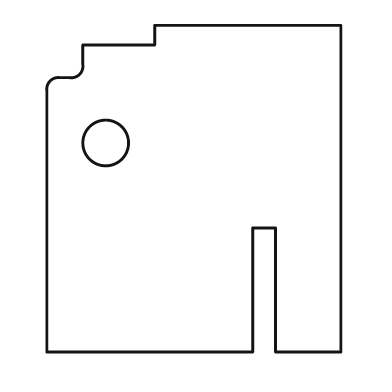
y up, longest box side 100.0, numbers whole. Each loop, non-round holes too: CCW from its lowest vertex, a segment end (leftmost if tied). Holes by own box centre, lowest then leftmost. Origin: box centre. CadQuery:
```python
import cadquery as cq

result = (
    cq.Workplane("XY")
    .moveTo(-45.0, -50.0)
    .lineTo(18.0, -50.0)
    .lineTo(18.0, -12.0)
    .lineTo(25.0, -12.0)
    .lineTo(25.0, -50.0)
    .lineTo(45.0, -50.0)
    .lineTo(45.0, 50.0)
    .lineTo(-12.0, 50.0)
    .lineTo(-12.0, 44.0)
    .lineTo(-34.0, 44.0)
    .lineTo(-34.0, 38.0)
    .threePointArc((-35.0, 35.0), (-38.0, 34.0))
    .lineTo(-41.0, 34.0)
    .threePointArc((-44.0, 33.0), (-45.0, 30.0))
    .close()
    .moveTo(-27.0, 14.0)
    .circle(7.0)
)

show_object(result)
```